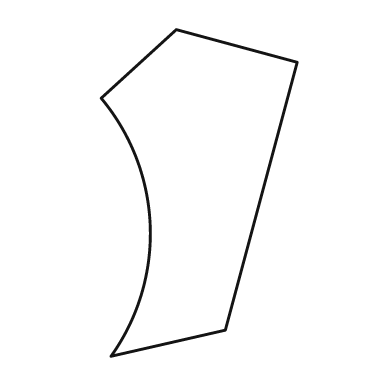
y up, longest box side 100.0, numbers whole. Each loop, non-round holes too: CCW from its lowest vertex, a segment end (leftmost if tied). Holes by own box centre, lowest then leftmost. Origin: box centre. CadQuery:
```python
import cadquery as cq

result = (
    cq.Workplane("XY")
    .moveTo(-27.0, -50.0)
    .lineTo(8.0, -42.0)
    .lineTo(30.0, 40.0)
    .lineTo(-7.0, 50.0)
    .lineTo(-30.0, 29.0)
    .threePointArc((-15.0, -10.0), (-27.0, -50.0))
    .close()
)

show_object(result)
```